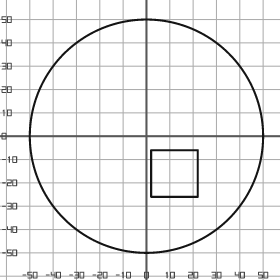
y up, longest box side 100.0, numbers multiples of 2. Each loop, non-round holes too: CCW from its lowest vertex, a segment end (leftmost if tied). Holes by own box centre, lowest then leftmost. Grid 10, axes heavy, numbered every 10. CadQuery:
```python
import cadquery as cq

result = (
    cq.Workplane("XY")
    .moveTo(0.0, 0.0)
    .circle(50.0)
    .moveTo(2.0, -26.0)
    .lineTo(22.0, -26.0)
    .lineTo(22.0, -6.0)
    .lineTo(2.0, -6.0)
    .close()
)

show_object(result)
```